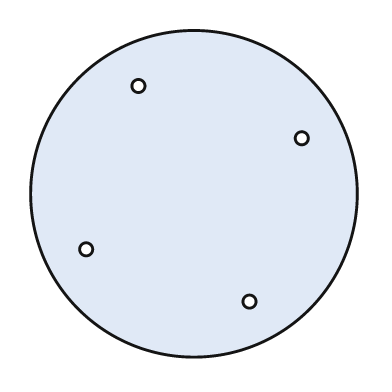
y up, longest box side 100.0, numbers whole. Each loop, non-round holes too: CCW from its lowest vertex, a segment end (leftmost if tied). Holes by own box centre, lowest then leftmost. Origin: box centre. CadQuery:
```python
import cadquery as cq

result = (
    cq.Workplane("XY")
    .moveTo(0.0, 0.0)
    .circle(50.0)
    .moveTo(17.0, -33.0)
    .circle(2.0)
    .moveTo(-33.0, -17.0)
    .circle(2.0)
    .moveTo(33.0, 17.0)
    .circle(2.0)
    .moveTo(-17.0, 33.0)
    .circle(2.0)
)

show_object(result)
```